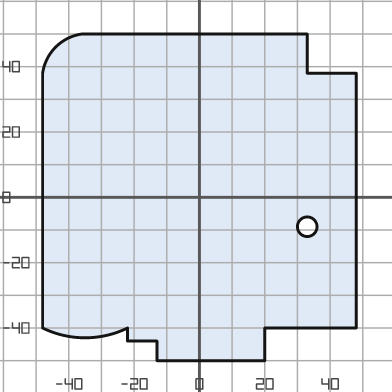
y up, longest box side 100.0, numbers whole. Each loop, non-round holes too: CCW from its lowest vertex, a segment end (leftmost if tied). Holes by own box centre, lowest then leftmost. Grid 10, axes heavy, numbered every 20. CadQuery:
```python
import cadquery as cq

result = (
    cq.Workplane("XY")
    .moveTo(-13.0, -50.0)
    .lineTo(20.0, -50.0)
    .lineTo(20.0, -40.0)
    .lineTo(48.0, -40.0)
    .lineTo(48.0, 38.0)
    .lineTo(33.0, 38.0)
    .lineTo(33.0, 50.0)
    .lineTo(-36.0, 50.0)
    .threePointArc((-44.0, 46.0), (-48.0, 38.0))
    .lineTo(-48.0, -40.0)
    .threePointArc((-35.0, -43.0), (-22.0, -40.0))
    .lineTo(-22.0, -44.0)
    .lineTo(-13.0, -44.0)
    .close()
    .moveTo(33.0, -9.0)
    .circle(3.0)
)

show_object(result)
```